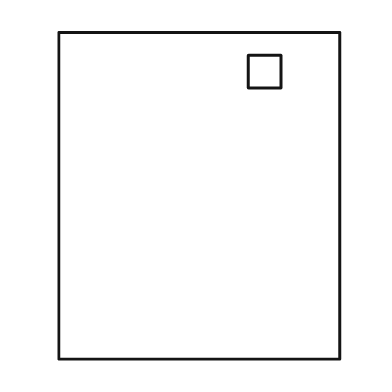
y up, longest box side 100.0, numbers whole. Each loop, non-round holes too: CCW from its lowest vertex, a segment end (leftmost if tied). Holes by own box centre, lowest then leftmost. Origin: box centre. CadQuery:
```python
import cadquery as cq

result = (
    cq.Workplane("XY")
    .moveTo(-43.0, -50.0)
    .lineTo(43.0, -50.0)
    .lineTo(43.0, 50.0)
    .lineTo(-43.0, 50.0)
    .close()
    .moveTo(15.0, 33.0)
    .lineTo(25.0, 33.0)
    .lineTo(25.0, 43.0)
    .lineTo(15.0, 43.0)
    .close()
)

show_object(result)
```